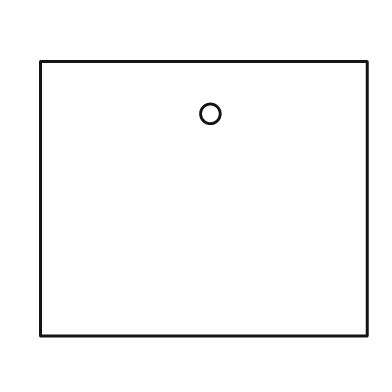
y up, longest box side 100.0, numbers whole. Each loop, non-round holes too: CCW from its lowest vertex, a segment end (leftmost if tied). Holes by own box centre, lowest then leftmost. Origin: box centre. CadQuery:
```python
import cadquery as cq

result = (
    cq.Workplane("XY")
    .moveTo(-50.0, -42.0)
    .lineTo(50.0, -42.0)
    .lineTo(50.0, 42.0)
    .lineTo(-50.0, 42.0)
    .close()
    .moveTo(2.0, 26.0)
    .circle(3.0)
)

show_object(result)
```